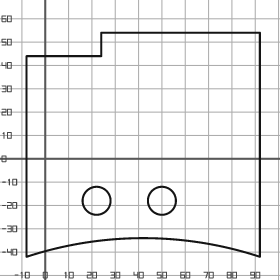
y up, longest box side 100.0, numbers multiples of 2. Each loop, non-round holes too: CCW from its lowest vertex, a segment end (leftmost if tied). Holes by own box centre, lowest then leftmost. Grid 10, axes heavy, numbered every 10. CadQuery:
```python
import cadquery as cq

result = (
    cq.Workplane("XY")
    .moveTo(-8.0, -42.0)
    .threePointArc((42.0, -34.0), (92.0, -42.0))
    .lineTo(92.0, 54.0)
    .lineTo(24.0, 54.0)
    .lineTo(24.0, 44.0)
    .lineTo(-8.0, 44.0)
    .close()
    .moveTo(22.0, -18.0)
    .circle(6.0)
    .moveTo(50.0, -18.0)
    .circle(6.0)
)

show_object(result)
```